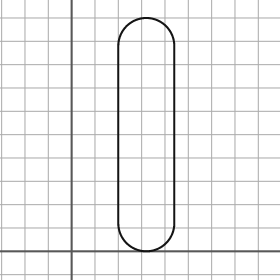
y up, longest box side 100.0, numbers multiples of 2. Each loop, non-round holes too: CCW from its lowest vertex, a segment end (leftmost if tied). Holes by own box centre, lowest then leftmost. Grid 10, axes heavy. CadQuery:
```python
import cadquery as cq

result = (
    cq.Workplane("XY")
    .moveTo(20.0, 12.0)
    .threePointArc((32.0, 0.0), (44.0, 12.0))
    .lineTo(44.0, 88.0)
    .threePointArc((32.0, 100.0), (20.0, 88.0))
    .close()
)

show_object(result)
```